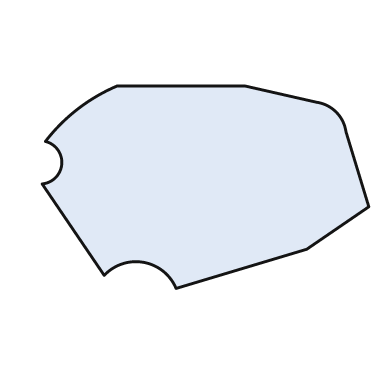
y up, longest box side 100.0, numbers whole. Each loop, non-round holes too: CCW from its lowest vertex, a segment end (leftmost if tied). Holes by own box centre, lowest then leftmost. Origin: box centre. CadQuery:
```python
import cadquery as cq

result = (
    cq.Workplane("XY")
    .moveTo(-9.0, -31.0)
    .lineTo(31.0, -19.0)
    .lineTo(50.0, -6.0)
    .lineTo(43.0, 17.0)
    .threePointArc((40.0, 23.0), (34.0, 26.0))
    .lineTo(12.0, 31.0)
    .lineTo(-27.0, 31.0)
    .threePointArc((-39.0, 24.0), (-49.0, 14.0))
    .threePointArc((-44.0, 7.0), (-50.0, 1.0))
    .lineTo(-31.0, -27.0)
    .threePointArc((-19.0, -23.0), (-9.0, -31.0))
    .close()
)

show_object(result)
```